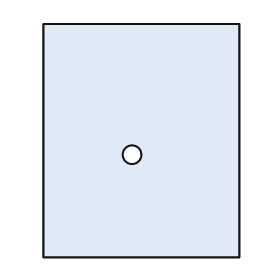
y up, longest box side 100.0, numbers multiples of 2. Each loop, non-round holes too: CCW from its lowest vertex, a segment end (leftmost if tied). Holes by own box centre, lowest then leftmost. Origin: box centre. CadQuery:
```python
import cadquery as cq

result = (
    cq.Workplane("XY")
    .moveTo(-42.0, -50.0)
    .lineTo(42.0, -50.0)
    .lineTo(42.0, 50.0)
    .lineTo(-42.0, 50.0)
    .close()
    .moveTo(-4.0, -6.0)
    .circle(4.0)
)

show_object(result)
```